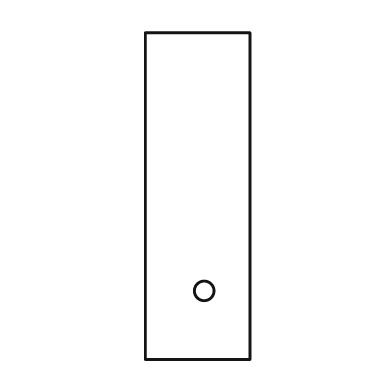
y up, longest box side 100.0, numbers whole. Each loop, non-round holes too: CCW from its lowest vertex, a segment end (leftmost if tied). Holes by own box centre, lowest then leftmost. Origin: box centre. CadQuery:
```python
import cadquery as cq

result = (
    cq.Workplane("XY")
    .moveTo(-16.0, -50.0)
    .lineTo(16.0, -50.0)
    .lineTo(16.0, 50.0)
    .lineTo(-16.0, 50.0)
    .close()
    .moveTo(2.0, -29.0)
    .circle(3.0)
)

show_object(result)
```